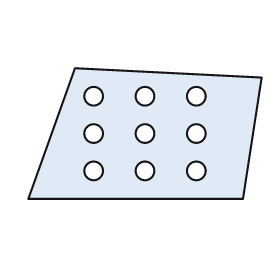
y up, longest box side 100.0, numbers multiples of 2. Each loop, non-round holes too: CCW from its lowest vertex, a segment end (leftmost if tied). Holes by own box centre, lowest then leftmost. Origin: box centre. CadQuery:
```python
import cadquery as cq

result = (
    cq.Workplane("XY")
    .moveTo(-50.0, -28.0)
    .lineTo(42.0, -28.0)
    .lineTo(50.0, 24.0)
    .lineTo(-30.0, 28.0)
    .close()
    .moveTo(-22.0, -16.0)
    .circle(4.0)
    .moveTo(0.0, -16.0)
    .circle(4.0)
    .moveTo(22.0, -16.0)
    .circle(4.0)
    .moveTo(-22.0, 0.0)
    .circle(4.0)
    .moveTo(0.0, 0.0)
    .circle(4.0)
    .moveTo(22.0, 0.0)
    .circle(4.0)
    .moveTo(-22.0, 16.0)
    .circle(4.0)
    .moveTo(0.0, 16.0)
    .circle(4.0)
    .moveTo(22.0, 16.0)
    .circle(4.0)
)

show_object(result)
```